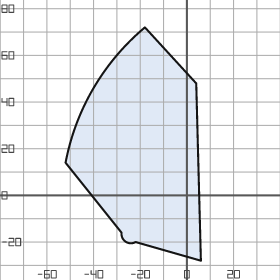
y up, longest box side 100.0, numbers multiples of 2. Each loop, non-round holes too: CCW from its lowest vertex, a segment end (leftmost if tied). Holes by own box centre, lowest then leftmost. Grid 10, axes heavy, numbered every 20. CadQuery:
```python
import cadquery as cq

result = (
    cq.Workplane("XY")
    .moveTo(6.0, -28.0)
    .lineTo(4.0, 48.0)
    .lineTo(-18.0, 72.0)
    .threePointArc((-40.0, 46.0), (-52.0, 14.0))
    .lineTo(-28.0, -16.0)
    .threePointArc((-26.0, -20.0), (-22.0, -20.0))
    .close()
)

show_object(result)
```